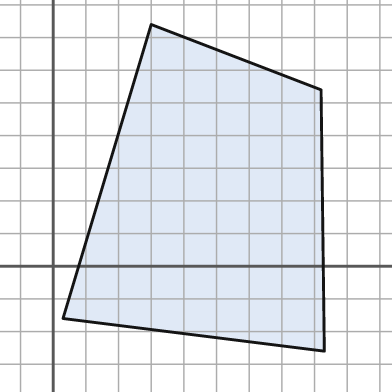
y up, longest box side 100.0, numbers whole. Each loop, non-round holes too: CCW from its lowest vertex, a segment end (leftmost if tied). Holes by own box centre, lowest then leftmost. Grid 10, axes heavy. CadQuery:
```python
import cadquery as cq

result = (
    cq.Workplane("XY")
    .moveTo(83.0, -26.0)
    .lineTo(82.0, 54.0)
    .lineTo(30.0, 74.0)
    .lineTo(3.0, -16.0)
    .close()
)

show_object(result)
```